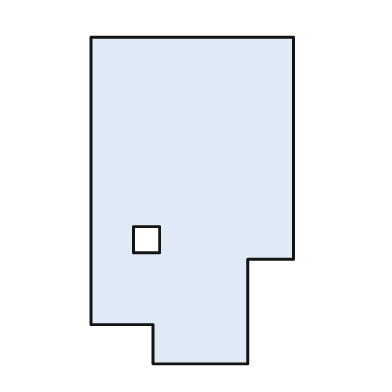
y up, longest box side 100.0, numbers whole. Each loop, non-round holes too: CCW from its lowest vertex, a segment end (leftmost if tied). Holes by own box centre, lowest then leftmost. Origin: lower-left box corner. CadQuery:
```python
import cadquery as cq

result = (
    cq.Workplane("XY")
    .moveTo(19.0, 0.0)
    .lineTo(48.0, 0.0)
    .lineTo(48.0, 32.0)
    .lineTo(62.0, 32.0)
    .lineTo(62.0, 100.0)
    .lineTo(0.0, 100.0)
    .lineTo(0.0, 12.0)
    .lineTo(19.0, 12.0)
    .close()
    .moveTo(13.0, 34.0)
    .lineTo(21.0, 34.0)
    .lineTo(21.0, 42.0)
    .lineTo(13.0, 42.0)
    .close()
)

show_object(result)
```